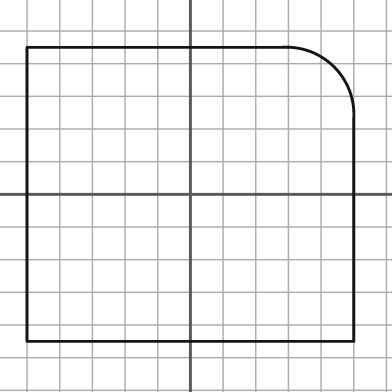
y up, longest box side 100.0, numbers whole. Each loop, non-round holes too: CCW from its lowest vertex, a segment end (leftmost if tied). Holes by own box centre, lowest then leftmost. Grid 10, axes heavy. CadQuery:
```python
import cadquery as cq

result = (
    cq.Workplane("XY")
    .moveTo(-50.0, -45.0)
    .lineTo(50.0, -45.0)
    .lineTo(50.0, 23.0)
    .threePointArc((44.0, 39.0), (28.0, 45.0))
    .lineTo(-50.0, 45.0)
    .close()
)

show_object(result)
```